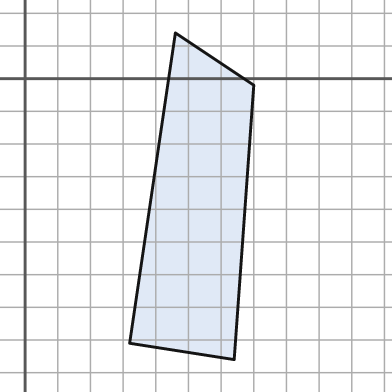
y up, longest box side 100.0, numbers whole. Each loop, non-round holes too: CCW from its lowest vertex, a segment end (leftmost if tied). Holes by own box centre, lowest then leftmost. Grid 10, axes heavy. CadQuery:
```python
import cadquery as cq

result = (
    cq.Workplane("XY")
    .moveTo(64.0, -86.0)
    .lineTo(70.0, -2.0)
    .lineTo(46.0, 14.0)
    .lineTo(32.0, -81.0)
    .close()
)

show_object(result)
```